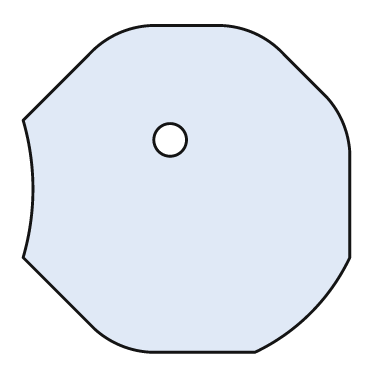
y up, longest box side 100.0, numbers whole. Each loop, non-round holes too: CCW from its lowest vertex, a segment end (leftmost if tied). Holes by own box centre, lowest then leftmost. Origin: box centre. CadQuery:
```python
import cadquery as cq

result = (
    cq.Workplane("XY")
    .moveTo(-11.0, -50.0)
    .lineTo(21.0, -50.0)
    .threePointArc((38.0, -38.0), (50.0, -21.0))
    .lineTo(50.0, 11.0)
    .threePointArc((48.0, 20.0), (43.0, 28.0))
    .lineTo(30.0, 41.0)
    .threePointArc((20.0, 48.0), (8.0, 50.0))
    .lineTo(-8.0, 50.0)
    .threePointArc((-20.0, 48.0), (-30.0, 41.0))
    .lineTo(-50.0, 21.0)
    .threePointArc((-47.0, 0.0), (-50.0, -21.0))
    .lineTo(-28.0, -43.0)
    .threePointArc((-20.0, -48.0), (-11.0, -50.0))
    .close()
    .moveTo(-5.0, 15.0)
    .circle(5.0)
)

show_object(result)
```